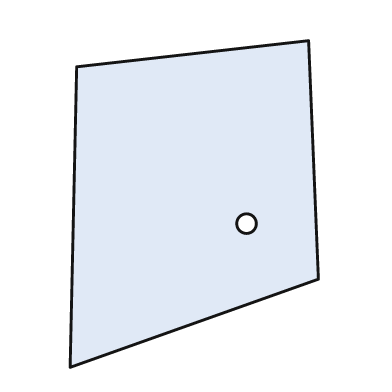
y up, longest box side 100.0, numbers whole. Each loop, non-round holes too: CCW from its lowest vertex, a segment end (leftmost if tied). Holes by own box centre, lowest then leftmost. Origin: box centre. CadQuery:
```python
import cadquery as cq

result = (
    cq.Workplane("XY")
    .moveTo(-38.0, -50.0)
    .lineTo(38.0, -23.0)
    .lineTo(35.0, 50.0)
    .lineTo(-36.0, 42.0)
    .close()
    .moveTo(16.0, -6.0)
    .circle(3.0)
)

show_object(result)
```